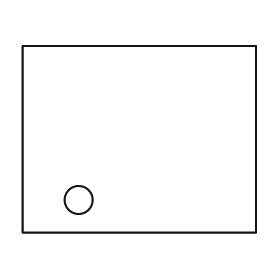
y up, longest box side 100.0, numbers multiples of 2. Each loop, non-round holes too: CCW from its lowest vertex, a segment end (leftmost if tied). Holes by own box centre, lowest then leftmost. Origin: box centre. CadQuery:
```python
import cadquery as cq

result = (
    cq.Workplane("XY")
    .moveTo(-50.0, -40.0)
    .lineTo(50.0, -40.0)
    .lineTo(50.0, 40.0)
    .lineTo(-50.0, 40.0)
    .close()
    .moveTo(-26.0, -26.0)
    .circle(6.0)
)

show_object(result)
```